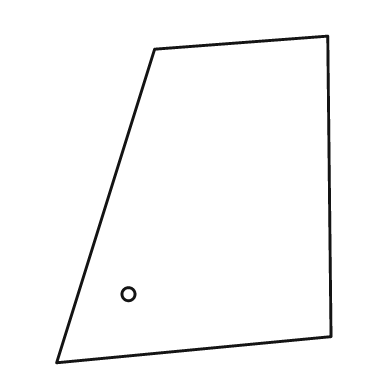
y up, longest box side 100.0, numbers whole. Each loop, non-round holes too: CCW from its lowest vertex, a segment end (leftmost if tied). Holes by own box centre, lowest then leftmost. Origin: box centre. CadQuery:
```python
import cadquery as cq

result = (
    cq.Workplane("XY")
    .moveTo(-42.0, -50.0)
    .lineTo(42.0, -42.0)
    .lineTo(41.0, 50.0)
    .lineTo(-12.0, 46.0)
    .close()
    .moveTo(-20.0, -29.0)
    .circle(2.0)
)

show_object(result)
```